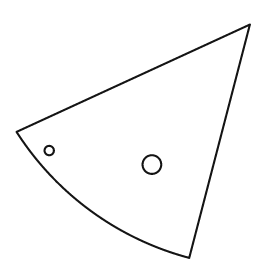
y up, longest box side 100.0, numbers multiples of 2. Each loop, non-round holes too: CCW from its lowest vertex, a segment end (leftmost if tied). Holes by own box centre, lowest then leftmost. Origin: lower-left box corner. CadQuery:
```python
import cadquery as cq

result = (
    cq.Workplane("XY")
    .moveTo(74.0, 0.0)
    .lineTo(100.0, 100.0)
    .lineTo(0.0, 54.0)
    .threePointArc((32.0, 20.0), (74.0, 0.0))
    .close()
    .moveTo(58.0, 40.0)
    .circle(4.0)
    .moveTo(14.0, 46.0)
    .circle(2.0)
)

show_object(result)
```